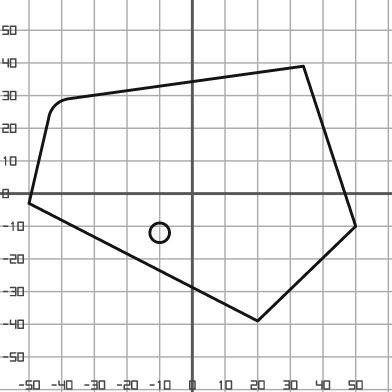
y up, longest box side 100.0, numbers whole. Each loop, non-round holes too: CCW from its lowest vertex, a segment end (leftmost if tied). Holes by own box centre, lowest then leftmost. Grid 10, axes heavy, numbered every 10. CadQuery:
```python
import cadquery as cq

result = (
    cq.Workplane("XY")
    .moveTo(20.0, -39.0)
    .lineTo(50.0, -10.0)
    .lineTo(34.0, 39.0)
    .lineTo(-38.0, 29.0)
    .threePointArc((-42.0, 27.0), (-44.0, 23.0))
    .lineTo(-50.0, -3.0)
    .close()
    .moveTo(-10.0, -12.0)
    .circle(3.0)
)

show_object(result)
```